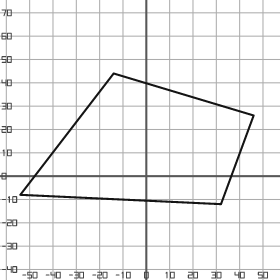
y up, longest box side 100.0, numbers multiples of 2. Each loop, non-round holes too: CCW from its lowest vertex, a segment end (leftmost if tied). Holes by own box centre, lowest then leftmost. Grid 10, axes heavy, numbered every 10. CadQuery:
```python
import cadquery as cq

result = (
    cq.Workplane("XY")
    .moveTo(32.0, -12.0)
    .lineTo(46.0, 26.0)
    .lineTo(-14.0, 44.0)
    .lineTo(-54.0, -8.0)
    .close()
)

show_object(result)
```